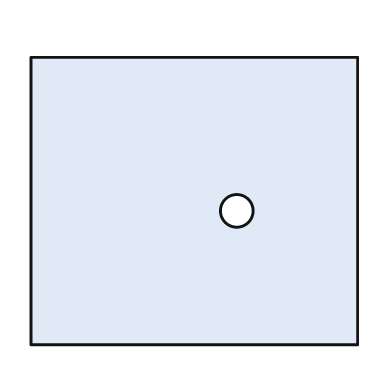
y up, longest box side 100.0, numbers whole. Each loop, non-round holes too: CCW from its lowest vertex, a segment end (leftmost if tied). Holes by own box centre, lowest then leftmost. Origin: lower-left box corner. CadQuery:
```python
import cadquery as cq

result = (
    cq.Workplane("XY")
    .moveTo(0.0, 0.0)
    .lineTo(100.0, 0.0)
    .lineTo(100.0, 88.0)
    .lineTo(0.0, 88.0)
    .close()
    .moveTo(63.0, 41.0)
    .circle(5.0)
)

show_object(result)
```